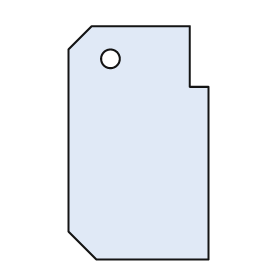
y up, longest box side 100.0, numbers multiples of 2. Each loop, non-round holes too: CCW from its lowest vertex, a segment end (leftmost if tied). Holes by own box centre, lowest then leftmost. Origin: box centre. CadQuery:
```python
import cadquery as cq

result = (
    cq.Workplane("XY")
    .moveTo(-18.0, -50.0)
    .lineTo(30.0, -50.0)
    .lineTo(30.0, 24.0)
    .lineTo(22.0, 24.0)
    .lineTo(22.0, 50.0)
    .lineTo(-20.0, 50.0)
    .lineTo(-30.0, 40.0)
    .lineTo(-30.0, -38.0)
    .close()
    .moveTo(-12.0, 36.0)
    .circle(4.0)
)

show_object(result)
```